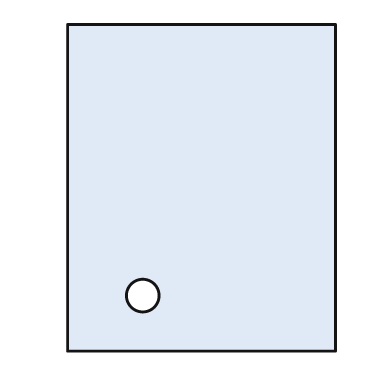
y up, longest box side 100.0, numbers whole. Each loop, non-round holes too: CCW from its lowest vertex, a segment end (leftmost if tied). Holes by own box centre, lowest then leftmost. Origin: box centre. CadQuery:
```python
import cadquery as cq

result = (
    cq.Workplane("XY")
    .moveTo(-41.0, -50.0)
    .lineTo(41.0, -50.0)
    .lineTo(41.0, 50.0)
    .lineTo(-41.0, 50.0)
    .close()
    .moveTo(-18.0, -33.0)
    .circle(5.0)
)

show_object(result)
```